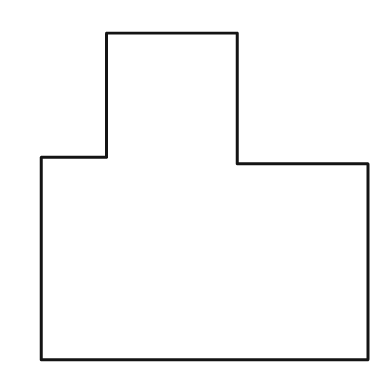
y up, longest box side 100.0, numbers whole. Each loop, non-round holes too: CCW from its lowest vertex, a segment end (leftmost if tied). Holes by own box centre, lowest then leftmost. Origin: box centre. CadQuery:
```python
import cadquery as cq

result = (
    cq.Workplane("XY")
    .moveTo(-50.0, -50.0)
    .lineTo(50.0, -50.0)
    .lineTo(50.0, 10.0)
    .lineTo(10.0, 10.0)
    .lineTo(10.0, 50.0)
    .lineTo(-30.0, 50.0)
    .lineTo(-30.0, 12.0)
    .lineTo(-50.0, 12.0)
    .close()
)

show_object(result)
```